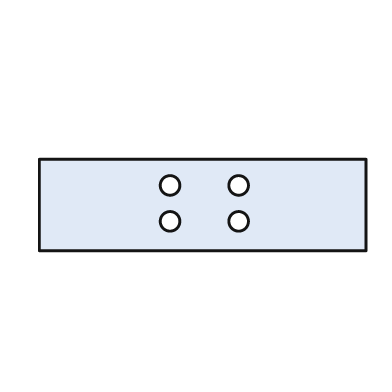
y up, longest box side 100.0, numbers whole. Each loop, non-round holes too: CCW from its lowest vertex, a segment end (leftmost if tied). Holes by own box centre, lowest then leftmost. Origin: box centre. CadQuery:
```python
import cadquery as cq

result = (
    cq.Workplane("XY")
    .moveTo(-50.0, -14.0)
    .lineTo(50.0, -14.0)
    .lineTo(50.0, 14.0)
    .lineTo(-50.0, 14.0)
    .close()
    .moveTo(-10.0, -5.0)
    .circle(3.0)
    .moveTo(11.0, -5.0)
    .circle(3.0)
    .moveTo(-10.0, 6.0)
    .circle(3.0)
    .moveTo(11.0, 6.0)
    .circle(3.0)
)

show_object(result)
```